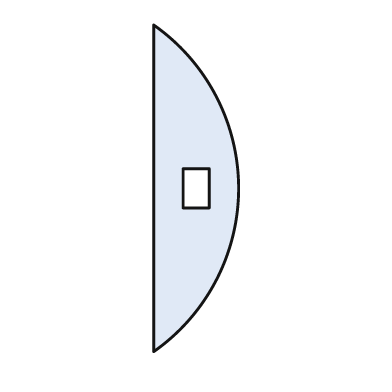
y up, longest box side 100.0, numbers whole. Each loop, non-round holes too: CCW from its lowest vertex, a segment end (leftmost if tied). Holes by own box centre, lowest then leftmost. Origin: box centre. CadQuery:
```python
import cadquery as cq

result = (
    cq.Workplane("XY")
    .moveTo(-13.0, -50.0)
    .threePointArc((13.0, 0.0), (-13.0, 50.0))
    .close()
    .moveTo(-4.0, -6.0)
    .lineTo(4.0, -6.0)
    .lineTo(4.0, 6.0)
    .lineTo(-4.0, 6.0)
    .close()
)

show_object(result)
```